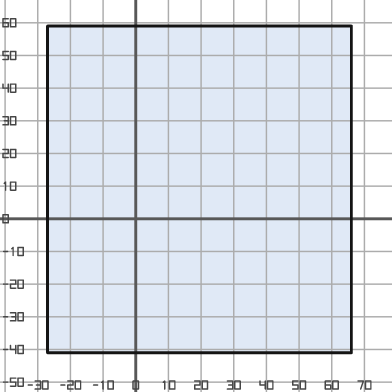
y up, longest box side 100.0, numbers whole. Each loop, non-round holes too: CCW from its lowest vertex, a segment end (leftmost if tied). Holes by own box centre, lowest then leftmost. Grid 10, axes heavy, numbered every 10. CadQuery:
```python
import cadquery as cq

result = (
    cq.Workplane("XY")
    .moveTo(-27.0, -41.0)
    .lineTo(66.0, -41.0)
    .lineTo(66.0, 59.0)
    .lineTo(-27.0, 59.0)
    .close()
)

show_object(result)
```